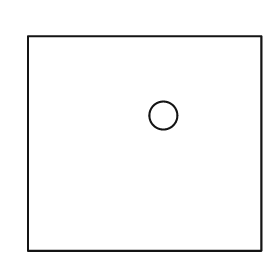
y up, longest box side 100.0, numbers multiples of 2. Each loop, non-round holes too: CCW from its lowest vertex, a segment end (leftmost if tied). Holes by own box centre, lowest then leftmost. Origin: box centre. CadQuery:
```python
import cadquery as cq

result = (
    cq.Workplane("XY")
    .moveTo(-50.0, -46.0)
    .lineTo(50.0, -46.0)
    .lineTo(50.0, 46.0)
    .lineTo(-50.0, 46.0)
    .close()
    .moveTo(8.0, 12.0)
    .circle(6.0)
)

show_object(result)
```